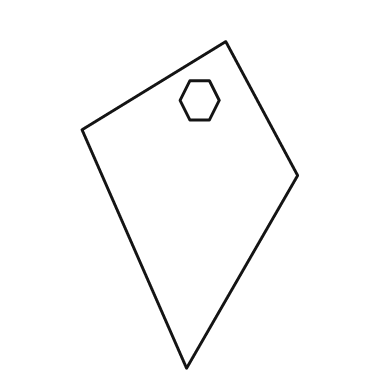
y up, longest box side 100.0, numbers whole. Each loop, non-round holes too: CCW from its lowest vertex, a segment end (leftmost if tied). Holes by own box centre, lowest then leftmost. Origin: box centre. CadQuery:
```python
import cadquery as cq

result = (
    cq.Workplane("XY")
    .moveTo(-1.0, -50.0)
    .lineTo(33.0, 9.0)
    .lineTo(11.0, 50.0)
    .lineTo(-33.0, 23.0)
    .close()
    .moveTo(0.0, 26.0)
    .lineTo(6.0, 26.0)
    .lineTo(9.0, 32.0)
    .lineTo(6.0, 38.0)
    .lineTo(0.0, 38.0)
    .lineTo(-3.0, 32.0)
    .close()
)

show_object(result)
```